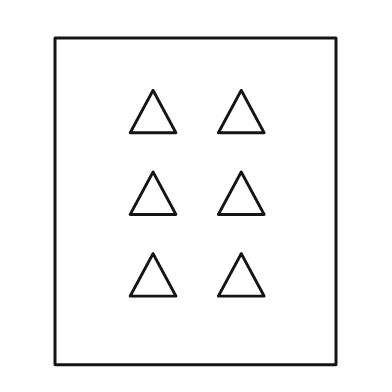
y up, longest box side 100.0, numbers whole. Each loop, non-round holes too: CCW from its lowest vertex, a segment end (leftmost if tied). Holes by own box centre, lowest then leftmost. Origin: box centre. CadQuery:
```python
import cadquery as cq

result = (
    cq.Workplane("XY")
    .moveTo(-43.0, -50.0)
    .lineTo(43.0, -50.0)
    .lineTo(43.0, 50.0)
    .lineTo(-43.0, 50.0)
    .close()
    .moveTo(-20.0, -29.0)
    .lineTo(-6.0, -29.0)
    .lineTo(-13.0, -16.0)
    .close()
    .moveTo(7.0, -29.0)
    .lineTo(21.0, -29.0)
    .lineTo(14.0, -16.0)
    .close()
    .moveTo(-20.0, -4.0)
    .lineTo(-6.0, -4.0)
    .lineTo(-13.0, 9.0)
    .close()
    .moveTo(7.0, -4.0)
    .lineTo(21.0, -4.0)
    .lineTo(14.0, 9.0)
    .close()
    .moveTo(-20.0, 21.0)
    .lineTo(-6.0, 21.0)
    .lineTo(-13.0, 34.0)
    .close()
    .moveTo(7.0, 21.0)
    .lineTo(21.0, 21.0)
    .lineTo(14.0, 34.0)
    .close()
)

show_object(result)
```